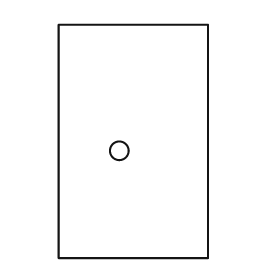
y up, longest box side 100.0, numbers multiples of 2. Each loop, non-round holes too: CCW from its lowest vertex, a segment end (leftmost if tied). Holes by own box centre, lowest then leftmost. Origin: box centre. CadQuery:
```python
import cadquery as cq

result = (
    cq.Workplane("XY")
    .moveTo(-32.0, -50.0)
    .lineTo(32.0, -50.0)
    .lineTo(32.0, 50.0)
    .lineTo(-32.0, 50.0)
    .close()
    .moveTo(-6.0, -4.0)
    .circle(4.0)
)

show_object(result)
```